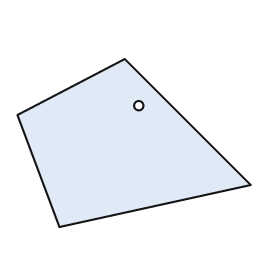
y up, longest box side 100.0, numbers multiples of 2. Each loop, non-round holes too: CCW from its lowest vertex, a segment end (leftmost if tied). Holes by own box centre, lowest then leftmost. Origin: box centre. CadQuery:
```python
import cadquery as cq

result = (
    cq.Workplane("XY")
    .moveTo(-32.0, -36.0)
    .lineTo(50.0, -18.0)
    .lineTo(-4.0, 36.0)
    .lineTo(-50.0, 12.0)
    .close()
    .moveTo(2.0, 16.0)
    .circle(2.0)
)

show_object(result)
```